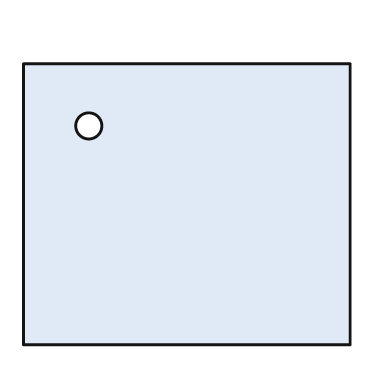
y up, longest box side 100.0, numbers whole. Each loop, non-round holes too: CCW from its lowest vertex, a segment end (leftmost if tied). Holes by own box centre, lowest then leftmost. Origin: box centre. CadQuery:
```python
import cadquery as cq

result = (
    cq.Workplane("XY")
    .moveTo(-50.0, -43.0)
    .lineTo(50.0, -43.0)
    .lineTo(50.0, 43.0)
    .lineTo(-50.0, 43.0)
    .close()
    .moveTo(-30.0, 24.0)
    .circle(4.0)
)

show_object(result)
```